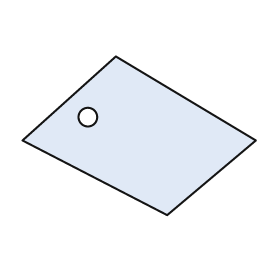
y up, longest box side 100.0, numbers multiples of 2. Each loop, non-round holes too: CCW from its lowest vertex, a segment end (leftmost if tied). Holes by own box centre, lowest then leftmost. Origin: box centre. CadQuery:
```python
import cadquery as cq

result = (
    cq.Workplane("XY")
    .moveTo(12.0, -34.0)
    .lineTo(50.0, -2.0)
    .lineTo(-10.0, 34.0)
    .lineTo(-50.0, -2.0)
    .close()
    .moveTo(-22.0, 8.0)
    .circle(4.0)
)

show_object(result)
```